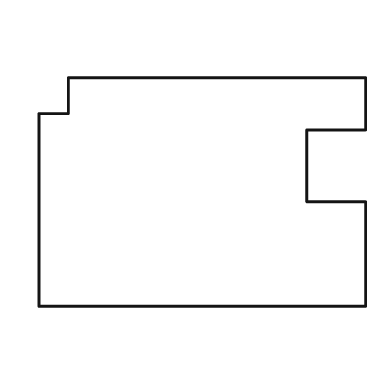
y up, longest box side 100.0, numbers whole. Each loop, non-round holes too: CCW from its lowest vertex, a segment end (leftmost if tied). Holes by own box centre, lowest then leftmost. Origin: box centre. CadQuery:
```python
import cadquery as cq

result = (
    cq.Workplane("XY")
    .moveTo(-50.0, -35.0)
    .lineTo(50.0, -35.0)
    .lineTo(50.0, -3.0)
    .lineTo(32.0, -3.0)
    .lineTo(32.0, 19.0)
    .lineTo(50.0, 19.0)
    .lineTo(50.0, 35.0)
    .lineTo(-41.0, 35.0)
    .lineTo(-41.0, 24.0)
    .lineTo(-50.0, 24.0)
    .close()
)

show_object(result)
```